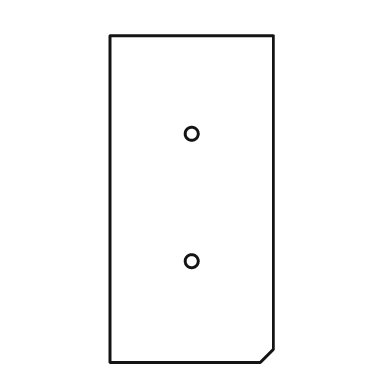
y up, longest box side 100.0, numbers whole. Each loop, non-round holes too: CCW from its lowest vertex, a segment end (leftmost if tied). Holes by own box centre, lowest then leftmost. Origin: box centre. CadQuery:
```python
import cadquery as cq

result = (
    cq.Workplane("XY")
    .moveTo(-25.0, -50.0)
    .lineTo(21.0, -50.0)
    .lineTo(25.0, -46.0)
    .lineTo(25.0, 50.0)
    .lineTo(-25.0, 50.0)
    .close()
    .moveTo(0.0, -19.0)
    .circle(2.0)
    .moveTo(0.0, 20.0)
    .circle(2.0)
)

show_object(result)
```